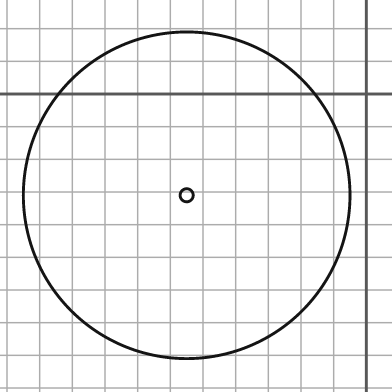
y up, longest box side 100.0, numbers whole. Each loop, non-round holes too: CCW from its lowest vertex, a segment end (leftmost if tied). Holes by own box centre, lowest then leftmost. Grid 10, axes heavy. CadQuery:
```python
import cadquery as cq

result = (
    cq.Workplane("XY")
    .moveTo(-55.0, -31.0)
    .circle(50.0)
    .moveTo(-55.0, -31.0)
    .circle(2.0)
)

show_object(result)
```